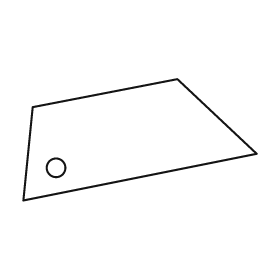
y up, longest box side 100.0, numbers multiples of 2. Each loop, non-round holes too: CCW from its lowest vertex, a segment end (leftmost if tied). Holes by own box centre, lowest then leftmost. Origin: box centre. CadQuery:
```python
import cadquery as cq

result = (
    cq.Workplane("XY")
    .moveTo(-50.0, -26.0)
    .lineTo(50.0, -6.0)
    .lineTo(16.0, 26.0)
    .lineTo(-46.0, 14.0)
    .close()
    .moveTo(-36.0, -12.0)
    .circle(4.0)
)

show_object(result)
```